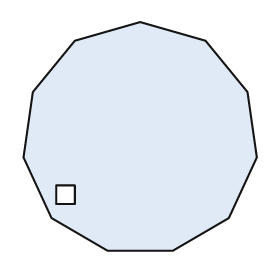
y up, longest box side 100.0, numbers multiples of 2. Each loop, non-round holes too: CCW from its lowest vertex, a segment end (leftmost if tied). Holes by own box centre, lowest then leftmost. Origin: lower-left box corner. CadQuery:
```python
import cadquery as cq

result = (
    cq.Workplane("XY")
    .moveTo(36.0, 0.0)
    .lineTo(64.0, 0.0)
    .lineTo(88.0, 14.0)
    .lineTo(100.0, 40.0)
    .lineTo(96.0, 68.0)
    .lineTo(78.0, 90.0)
    .lineTo(50.0, 98.0)
    .lineTo(22.0, 90.0)
    .lineTo(4.0, 68.0)
    .lineTo(0.0, 40.0)
    .lineTo(12.0, 14.0)
    .close()
    .moveTo(14.0, 20.0)
    .lineTo(22.0, 20.0)
    .lineTo(22.0, 28.0)
    .lineTo(14.0, 28.0)
    .close()
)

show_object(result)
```